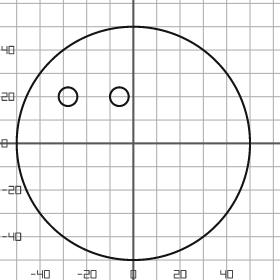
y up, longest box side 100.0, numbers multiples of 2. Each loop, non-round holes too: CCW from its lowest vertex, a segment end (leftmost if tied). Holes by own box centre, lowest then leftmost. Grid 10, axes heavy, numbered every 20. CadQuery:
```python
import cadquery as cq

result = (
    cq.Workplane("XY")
    .moveTo(0.0, 0.0)
    .circle(50.0)
    .moveTo(-28.0, 20.0)
    .circle(4.0)
    .moveTo(-6.0, 20.0)
    .circle(4.0)
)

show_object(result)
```